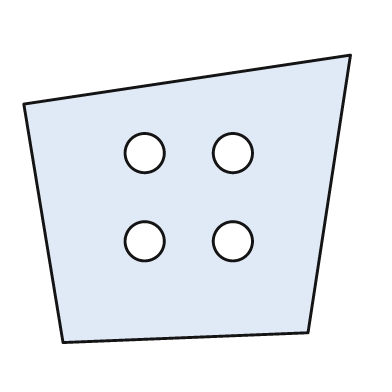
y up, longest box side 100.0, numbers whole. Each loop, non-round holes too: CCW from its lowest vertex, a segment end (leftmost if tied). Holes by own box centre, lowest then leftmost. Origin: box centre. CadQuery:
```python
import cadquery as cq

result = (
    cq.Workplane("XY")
    .moveTo(-38.0, -44.0)
    .lineTo(37.0, -41.0)
    .lineTo(50.0, 44.0)
    .lineTo(-50.0, 29.0)
    .close()
    .moveTo(-13.0, -13.0)
    .circle(6.0)
    .moveTo(14.0, -13.0)
    .circle(6.0)
    .moveTo(-13.0, 14.0)
    .circle(6.0)
    .moveTo(14.0, 14.0)
    .circle(6.0)
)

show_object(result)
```